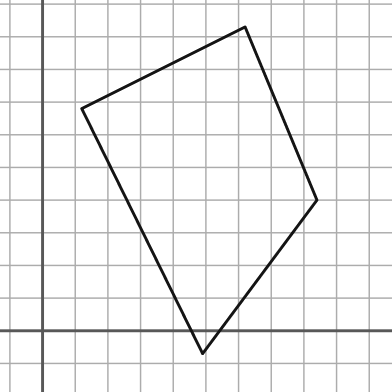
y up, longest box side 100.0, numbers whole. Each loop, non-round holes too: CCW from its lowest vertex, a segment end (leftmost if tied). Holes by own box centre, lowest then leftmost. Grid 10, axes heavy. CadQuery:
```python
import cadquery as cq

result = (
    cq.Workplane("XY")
    .moveTo(49.0, -7.0)
    .lineTo(84.0, 40.0)
    .lineTo(62.0, 93.0)
    .lineTo(12.0, 68.0)
    .close()
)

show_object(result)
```